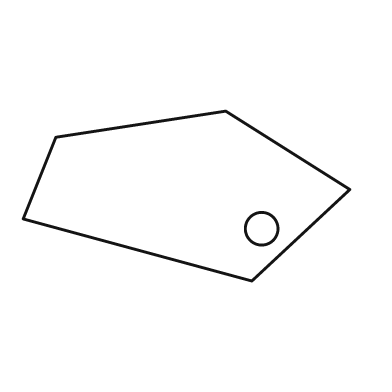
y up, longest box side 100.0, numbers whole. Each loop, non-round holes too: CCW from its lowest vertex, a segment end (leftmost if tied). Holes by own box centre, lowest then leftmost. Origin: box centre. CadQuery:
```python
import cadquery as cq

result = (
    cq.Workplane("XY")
    .moveTo(20.0, -26.0)
    .lineTo(50.0, 2.0)
    .lineTo(12.0, 26.0)
    .lineTo(-40.0, 18.0)
    .lineTo(-50.0, -7.0)
    .close()
    .moveTo(23.0, -10.0)
    .circle(5.0)
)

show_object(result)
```